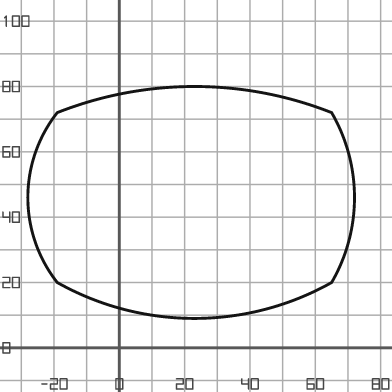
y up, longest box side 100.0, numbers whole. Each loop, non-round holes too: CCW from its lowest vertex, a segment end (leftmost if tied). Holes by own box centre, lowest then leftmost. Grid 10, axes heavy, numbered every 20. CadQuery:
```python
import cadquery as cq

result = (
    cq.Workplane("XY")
    .moveTo(-19.0, 20.0)
    .threePointArc((23.0, 9.0), (65.0, 20.0))
    .threePointArc((72.0, 46.0), (65.0, 72.0))
    .threePointArc((23.0, 80.0), (-19.0, 72.0))
    .threePointArc((-28.0, 46.0), (-19.0, 20.0))
    .close()
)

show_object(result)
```